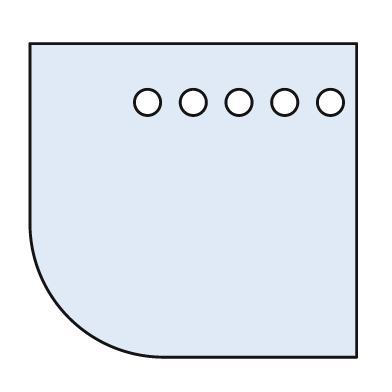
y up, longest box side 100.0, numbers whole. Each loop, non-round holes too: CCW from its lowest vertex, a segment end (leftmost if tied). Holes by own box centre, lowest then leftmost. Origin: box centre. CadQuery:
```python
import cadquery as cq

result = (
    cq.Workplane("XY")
    .moveTo(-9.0, -48.0)
    .lineTo(50.0, -48.0)
    .lineTo(50.0, 48.0)
    .lineTo(-50.0, 48.0)
    .lineTo(-50.0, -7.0)
    .threePointArc((-38.0, -36.0), (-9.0, -48.0))
    .close()
    .moveTo(-14.0, 30.0)
    .circle(4.0)
    .moveTo(0.0, 30.0)
    .circle(4.0)
    .moveTo(14.0, 30.0)
    .circle(4.0)
    .moveTo(28.0, 30.0)
    .circle(4.0)
    .moveTo(42.0, 30.0)
    .circle(4.0)
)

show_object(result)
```